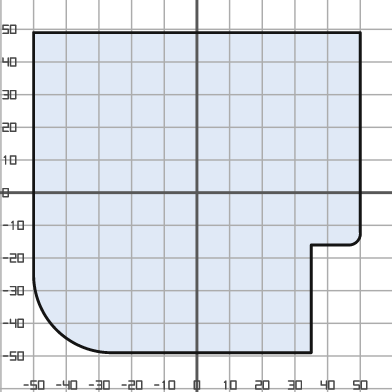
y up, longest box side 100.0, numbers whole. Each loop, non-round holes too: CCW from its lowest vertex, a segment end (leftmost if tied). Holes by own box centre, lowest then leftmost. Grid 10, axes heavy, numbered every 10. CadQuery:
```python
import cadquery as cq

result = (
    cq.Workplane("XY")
    .moveTo(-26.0, -49.0)
    .lineTo(35.0, -49.0)
    .lineTo(35.0, -16.0)
    .lineTo(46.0, -16.0)
    .threePointArc((49.0, -15.0), (50.0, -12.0))
    .lineTo(50.0, 49.0)
    .lineTo(-50.0, 49.0)
    .lineTo(-50.0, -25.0)
    .threePointArc((-43.0, -42.0), (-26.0, -49.0))
    .close()
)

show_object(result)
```